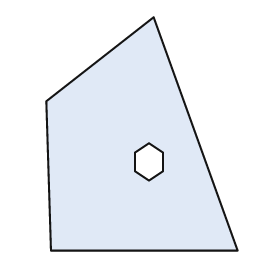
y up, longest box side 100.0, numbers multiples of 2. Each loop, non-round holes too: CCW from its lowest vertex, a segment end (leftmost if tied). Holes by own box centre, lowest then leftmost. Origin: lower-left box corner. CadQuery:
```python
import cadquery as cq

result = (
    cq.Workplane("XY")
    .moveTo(2.0, 0.0)
    .lineTo(82.0, 0.0)
    .lineTo(46.0, 100.0)
    .lineTo(0.0, 64.0)
    .close()
    .moveTo(44.0, 30.0)
    .lineTo(50.0, 34.0)
    .lineTo(50.0, 42.0)
    .lineTo(44.0, 46.0)
    .lineTo(38.0, 42.0)
    .lineTo(38.0, 34.0)
    .close()
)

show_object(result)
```